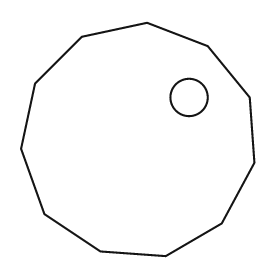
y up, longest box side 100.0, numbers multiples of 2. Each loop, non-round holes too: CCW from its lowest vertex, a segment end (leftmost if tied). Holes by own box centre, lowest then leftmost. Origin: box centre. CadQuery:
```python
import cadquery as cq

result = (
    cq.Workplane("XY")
    .moveTo(12.0, -50.0)
    .lineTo(36.0, -36.0)
    .lineTo(50.0, -10.0)
    .lineTo(48.0, 18.0)
    .lineTo(30.0, 40.0)
    .lineTo(4.0, 50.0)
    .lineTo(-24.0, 44.0)
    .lineTo(-44.0, 24.0)
    .lineTo(-50.0, -4.0)
    .lineTo(-40.0, -32.0)
    .lineTo(-16.0, -48.0)
    .close()
    .moveTo(22.0, 18.0)
    .circle(8.0)
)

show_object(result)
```